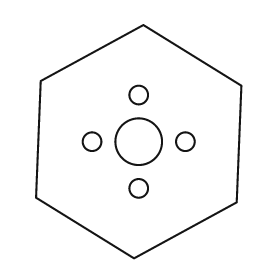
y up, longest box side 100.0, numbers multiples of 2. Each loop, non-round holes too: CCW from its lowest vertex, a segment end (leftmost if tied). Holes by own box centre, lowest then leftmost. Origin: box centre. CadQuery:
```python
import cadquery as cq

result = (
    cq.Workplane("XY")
    .moveTo(-2.0, -50.0)
    .lineTo(42.0, -26.0)
    .lineTo(44.0, 24.0)
    .lineTo(2.0, 50.0)
    .lineTo(-42.0, 26.0)
    .lineTo(-44.0, -24.0)
    .close()
    .moveTo(0.0, -20.0)
    .circle(4.0)
    .moveTo(-20.0, 0.0)
    .circle(4.0)
    .moveTo(0.0, 0.0)
    .circle(10.0)
    .moveTo(20.0, 0.0)
    .circle(4.0)
    .moveTo(0.0, 20.0)
    .circle(4.0)
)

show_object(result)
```